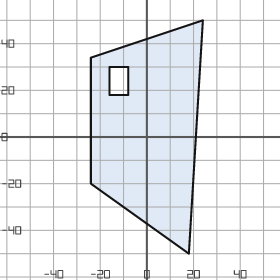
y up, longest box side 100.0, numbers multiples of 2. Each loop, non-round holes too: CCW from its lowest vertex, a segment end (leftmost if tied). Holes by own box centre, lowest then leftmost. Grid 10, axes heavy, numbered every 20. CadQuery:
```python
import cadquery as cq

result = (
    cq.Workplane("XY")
    .moveTo(18.0, -50.0)
    .lineTo(24.0, 50.0)
    .lineTo(-24.0, 34.0)
    .lineTo(-24.0, -20.0)
    .close()
    .moveTo(-16.0, 18.0)
    .lineTo(-8.0, 18.0)
    .lineTo(-8.0, 30.0)
    .lineTo(-16.0, 30.0)
    .close()
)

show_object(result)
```